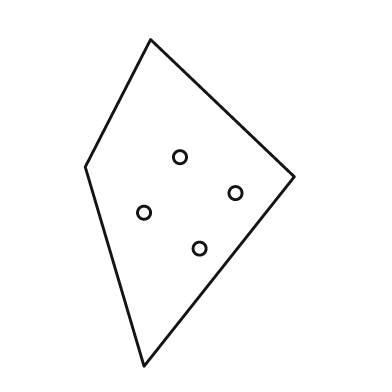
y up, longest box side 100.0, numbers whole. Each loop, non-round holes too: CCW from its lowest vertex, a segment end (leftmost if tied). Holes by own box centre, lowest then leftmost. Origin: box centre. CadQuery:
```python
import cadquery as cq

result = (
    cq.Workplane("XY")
    .moveTo(-14.0, -50.0)
    .lineTo(32.0, 8.0)
    .lineTo(-12.0, 50.0)
    .lineTo(-32.0, 11.0)
    .close()
    .moveTo(3.0, -14.0)
    .circle(2.0)
    .moveTo(-14.0, -3.0)
    .circle(2.0)
    .moveTo(14.0, 3.0)
    .circle(2.0)
    .moveTo(-3.0, 14.0)
    .circle(2.0)
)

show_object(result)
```